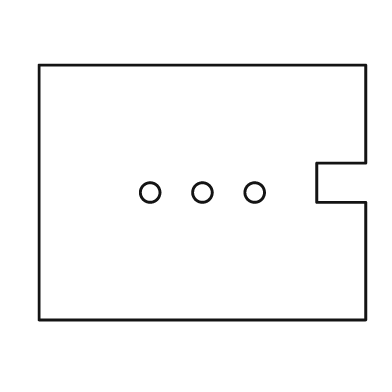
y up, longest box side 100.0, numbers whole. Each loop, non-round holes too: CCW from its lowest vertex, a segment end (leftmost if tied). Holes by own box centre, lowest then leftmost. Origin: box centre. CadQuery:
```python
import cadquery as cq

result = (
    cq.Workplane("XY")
    .moveTo(-50.0, -39.0)
    .lineTo(50.0, -39.0)
    .lineTo(50.0, -3.0)
    .lineTo(35.0, -3.0)
    .lineTo(35.0, 9.0)
    .lineTo(50.0, 9.0)
    .lineTo(50.0, 39.0)
    .lineTo(-50.0, 39.0)
    .close()
    .moveTo(-16.0, 0.0)
    .circle(3.0)
    .moveTo(0.0, 0.0)
    .circle(3.0)
    .moveTo(16.0, 0.0)
    .circle(3.0)
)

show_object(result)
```